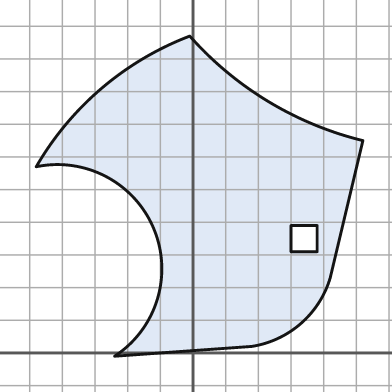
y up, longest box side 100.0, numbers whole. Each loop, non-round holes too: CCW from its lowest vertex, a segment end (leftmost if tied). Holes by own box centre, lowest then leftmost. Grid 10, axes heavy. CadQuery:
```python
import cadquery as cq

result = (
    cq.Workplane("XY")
    .moveTo(-24.0, -1.0)
    .lineTo(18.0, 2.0)
    .threePointArc((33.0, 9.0), (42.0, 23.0))
    .lineTo(52.0, 65.0)
    .threePointArc((23.0, 77.0), (-1.0, 97.0))
    .threePointArc((-28.0, 81.0), (-48.0, 57.0))
    .threePointArc((-12.0, 38.0), (-24.0, -1.0))
    .close()
    .moveTo(30.0, 31.0)
    .lineTo(38.0, 31.0)
    .lineTo(38.0, 39.0)
    .lineTo(30.0, 39.0)
    .close()
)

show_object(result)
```